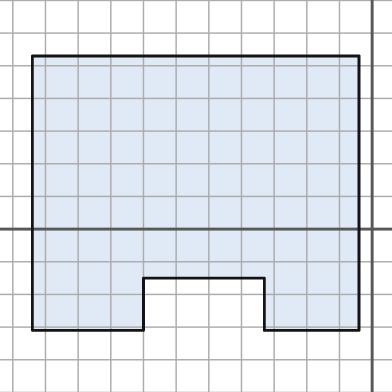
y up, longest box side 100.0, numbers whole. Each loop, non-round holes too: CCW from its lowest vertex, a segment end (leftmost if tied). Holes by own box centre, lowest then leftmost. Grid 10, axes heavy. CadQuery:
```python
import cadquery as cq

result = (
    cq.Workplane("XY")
    .moveTo(-104.0, -31.0)
    .lineTo(-70.0, -31.0)
    .lineTo(-70.0, -15.0)
    .lineTo(-33.0, -15.0)
    .lineTo(-33.0, -31.0)
    .lineTo(-4.0, -31.0)
    .lineTo(-4.0, 53.0)
    .lineTo(-104.0, 53.0)
    .close()
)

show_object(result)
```